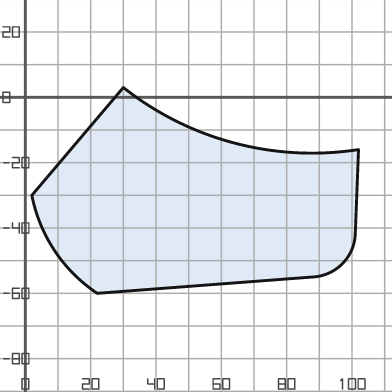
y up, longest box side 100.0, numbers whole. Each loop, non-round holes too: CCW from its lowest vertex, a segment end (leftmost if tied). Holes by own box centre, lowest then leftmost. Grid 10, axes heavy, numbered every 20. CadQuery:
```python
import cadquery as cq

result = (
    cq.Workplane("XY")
    .moveTo(22.0, -60.0)
    .lineTo(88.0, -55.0)
    .threePointArc((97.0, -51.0), (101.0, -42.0))
    .lineTo(102.0, -16.0)
    .threePointArc((64.0, -14.0), (30.0, 3.0))
    .lineTo(2.0, -30.0)
    .threePointArc((9.0, -47.0), (22.0, -60.0))
    .close()
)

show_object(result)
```